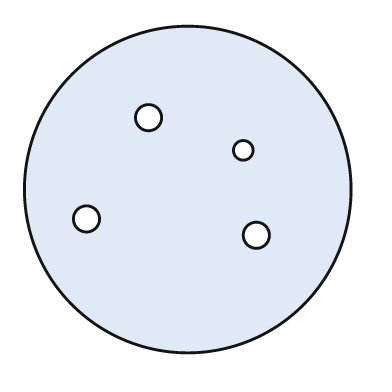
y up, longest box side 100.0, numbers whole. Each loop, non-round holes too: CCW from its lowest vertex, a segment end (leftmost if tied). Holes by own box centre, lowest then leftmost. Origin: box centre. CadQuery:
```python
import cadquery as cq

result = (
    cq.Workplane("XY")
    .moveTo(0.0, 0.0)
    .circle(50.0)
    .moveTo(21.0, -14.0)
    .circle(4.0)
    .moveTo(-31.0, -9.0)
    .circle(4.0)
    .moveTo(17.0, 12.0)
    .circle(3.0)
    .moveTo(-12.0, 22.0)
    .circle(4.0)
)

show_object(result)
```